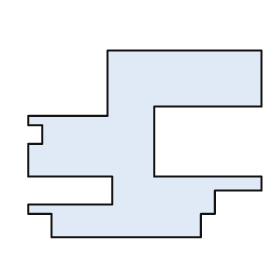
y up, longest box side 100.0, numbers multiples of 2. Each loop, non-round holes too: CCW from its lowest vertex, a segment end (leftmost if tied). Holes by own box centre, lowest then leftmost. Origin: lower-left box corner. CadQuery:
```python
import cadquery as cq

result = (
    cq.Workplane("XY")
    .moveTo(10.0, 0.0)
    .lineTo(74.0, 0.0)
    .lineTo(74.0, 10.0)
    .lineTo(80.0, 10.0)
    .lineTo(80.0, 20.0)
    .lineTo(100.0, 20.0)
    .lineTo(100.0, 26.0)
    .lineTo(54.0, 26.0)
    .lineTo(54.0, 56.0)
    .lineTo(100.0, 56.0)
    .lineTo(100.0, 80.0)
    .lineTo(34.0, 80.0)
    .lineTo(34.0, 52.0)
    .lineTo(0.0, 52.0)
    .lineTo(0.0, 48.0)
    .lineTo(6.0, 48.0)
    .lineTo(6.0, 40.0)
    .lineTo(0.0, 40.0)
    .lineTo(0.0, 26.0)
    .lineTo(36.0, 26.0)
    .lineTo(36.0, 14.0)
    .lineTo(0.0, 14.0)
    .lineTo(0.0, 10.0)
    .lineTo(10.0, 10.0)
    .close()
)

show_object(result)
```